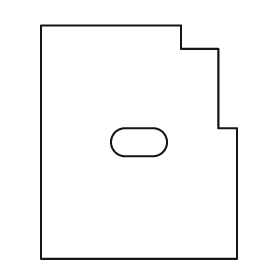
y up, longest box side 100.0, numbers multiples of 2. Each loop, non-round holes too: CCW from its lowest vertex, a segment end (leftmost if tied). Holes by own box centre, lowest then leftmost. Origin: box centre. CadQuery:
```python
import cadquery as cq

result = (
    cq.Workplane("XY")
    .moveTo(-42.0, -50.0)
    .lineTo(42.0, -50.0)
    .lineTo(42.0, 6.0)
    .lineTo(34.0, 6.0)
    .lineTo(34.0, 40.0)
    .lineTo(18.0, 40.0)
    .lineTo(18.0, 50.0)
    .lineTo(-42.0, 50.0)
    .close()
    .moveTo(-6.0, -6.0)
    .lineTo(6.0, -6.0)
    .threePointArc((12.0, 0.0), (6.0, 6.0))
    .lineTo(-6.0, 6.0)
    .threePointArc((-12.0, 0.0), (-6.0, -6.0))
    .close()
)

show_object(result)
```